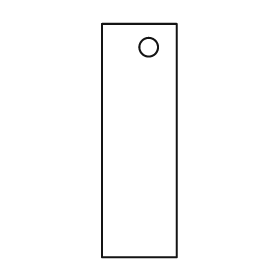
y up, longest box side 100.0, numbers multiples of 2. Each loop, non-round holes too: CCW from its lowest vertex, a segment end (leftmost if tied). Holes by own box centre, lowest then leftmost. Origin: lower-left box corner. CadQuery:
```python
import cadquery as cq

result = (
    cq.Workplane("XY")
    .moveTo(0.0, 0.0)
    .lineTo(32.0, 0.0)
    .lineTo(32.0, 100.0)
    .lineTo(0.0, 100.0)
    .close()
    .moveTo(20.0, 90.0)
    .circle(4.0)
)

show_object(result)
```